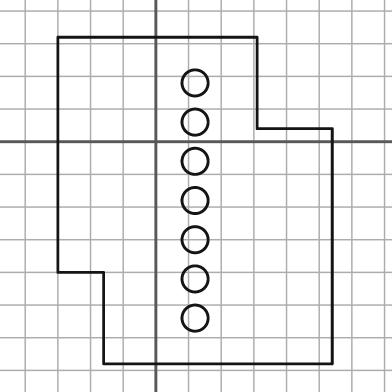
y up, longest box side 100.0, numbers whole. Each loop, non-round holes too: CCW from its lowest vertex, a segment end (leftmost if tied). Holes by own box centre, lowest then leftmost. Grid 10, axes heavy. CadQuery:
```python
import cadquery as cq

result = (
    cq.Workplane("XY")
    .moveTo(-16.0, -68.0)
    .lineTo(54.0, -68.0)
    .lineTo(54.0, 4.0)
    .lineTo(31.0, 4.0)
    .lineTo(31.0, 32.0)
    .lineTo(-30.0, 32.0)
    .lineTo(-30.0, -40.0)
    .lineTo(-16.0, -40.0)
    .close()
    .moveTo(12.0, -54.0)
    .circle(4.0)
    .moveTo(12.0, -42.0)
    .circle(4.0)
    .moveTo(12.0, -30.0)
    .circle(4.0)
    .moveTo(12.0, -18.0)
    .circle(4.0)
    .moveTo(12.0, -6.0)
    .circle(4.0)
    .moveTo(12.0, 6.0)
    .circle(4.0)
    .moveTo(12.0, 18.0)
    .circle(4.0)
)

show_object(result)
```